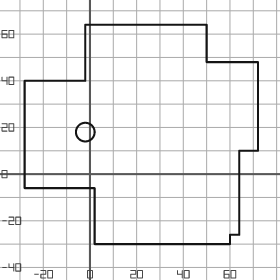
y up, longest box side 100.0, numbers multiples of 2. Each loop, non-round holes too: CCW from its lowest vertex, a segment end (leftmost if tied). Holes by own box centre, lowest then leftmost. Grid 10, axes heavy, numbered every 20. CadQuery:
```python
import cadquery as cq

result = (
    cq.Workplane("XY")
    .moveTo(2.0, -30.0)
    .lineTo(60.0, -30.0)
    .lineTo(60.0, -26.0)
    .lineTo(64.0, -26.0)
    .lineTo(64.0, 10.0)
    .lineTo(72.0, 10.0)
    .lineTo(72.0, 48.0)
    .lineTo(50.0, 48.0)
    .lineTo(50.0, 64.0)
    .lineTo(-2.0, 64.0)
    .lineTo(-2.0, 40.0)
    .lineTo(-28.0, 40.0)
    .lineTo(-28.0, -6.0)
    .lineTo(2.0, -6.0)
    .close()
    .moveTo(-2.0, 18.0)
    .circle(4.0)
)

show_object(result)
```